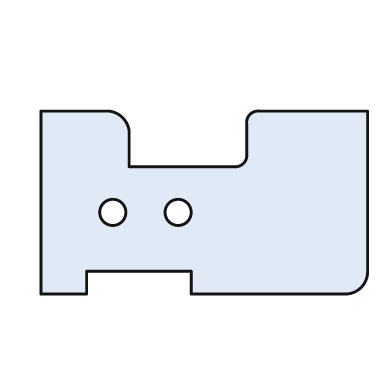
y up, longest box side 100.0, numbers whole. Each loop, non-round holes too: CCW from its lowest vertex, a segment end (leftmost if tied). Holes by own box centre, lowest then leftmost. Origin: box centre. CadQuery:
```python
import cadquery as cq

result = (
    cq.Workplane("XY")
    .moveTo(-50.0, -28.0)
    .lineTo(-36.0, -28.0)
    .lineTo(-36.0, -21.0)
    .lineTo(-4.0, -21.0)
    .lineTo(-4.0, -28.0)
    .lineTo(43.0, -28.0)
    .threePointArc((48.0, -26.0), (50.0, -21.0))
    .lineTo(50.0, 28.0)
    .lineTo(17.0, 28.0)
    .threePointArc((14.0, 27.0), (13.0, 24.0))
    .lineTo(13.0, 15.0)
    .threePointArc((12.0, 12.0), (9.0, 11.0))
    .lineTo(-23.0, 11.0)
    .lineTo(-23.0, 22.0)
    .threePointArc((-25.0, 26.0), (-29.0, 28.0))
    .lineTo(-50.0, 28.0)
    .close()
    .moveTo(-28.0, -3.0)
    .circle(4.0)
    .moveTo(-8.0, -3.0)
    .circle(4.0)
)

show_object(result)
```